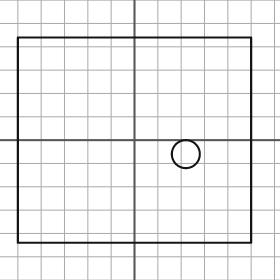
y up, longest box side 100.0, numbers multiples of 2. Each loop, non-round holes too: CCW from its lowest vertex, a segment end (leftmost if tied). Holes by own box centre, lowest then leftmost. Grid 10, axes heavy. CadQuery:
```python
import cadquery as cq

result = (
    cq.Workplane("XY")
    .moveTo(-50.0, -44.0)
    .lineTo(50.0, -44.0)
    .lineTo(50.0, 44.0)
    .lineTo(-50.0, 44.0)
    .close()
    .moveTo(22.0, -6.0)
    .circle(6.0)
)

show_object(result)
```